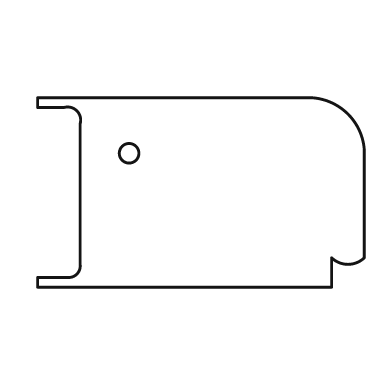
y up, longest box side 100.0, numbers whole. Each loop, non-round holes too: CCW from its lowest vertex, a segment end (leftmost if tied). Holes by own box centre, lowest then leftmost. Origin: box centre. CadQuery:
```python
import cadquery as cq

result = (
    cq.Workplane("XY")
    .moveTo(-50.0, -29.0)
    .lineTo(40.0, -29.0)
    .lineTo(40.0, -20.0)
    .threePointArc((45.0, -22.0), (50.0, -20.0))
    .lineTo(50.0, 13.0)
    .threePointArc((45.0, 24.0), (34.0, 29.0))
    .lineTo(-50.0, 29.0)
    .lineTo(-50.0, 26.0)
    .lineTo(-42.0, 26.0)
    .threePointArc((-38.0, 25.0), (-37.0, 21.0))
    .lineTo(-37.0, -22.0)
    .threePointArc((-38.0, -25.0), (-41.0, -26.0))
    .lineTo(-50.0, -26.0)
    .close()
    .moveTo(-22.0, 12.0)
    .circle(3.0)
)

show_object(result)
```